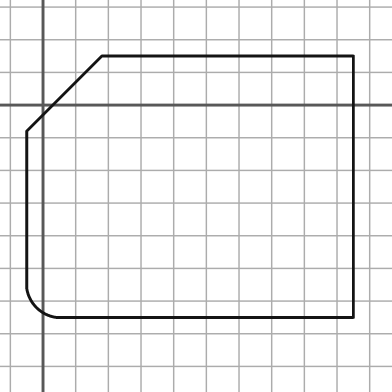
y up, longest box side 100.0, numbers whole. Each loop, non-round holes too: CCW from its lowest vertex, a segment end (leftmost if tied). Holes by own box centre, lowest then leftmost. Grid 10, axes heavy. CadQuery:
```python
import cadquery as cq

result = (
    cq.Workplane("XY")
    .moveTo(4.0, -65.0)
    .lineTo(95.0, -65.0)
    .lineTo(95.0, 15.0)
    .lineTo(18.0, 15.0)
    .lineTo(-5.0, -8.0)
    .lineTo(-5.0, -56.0)
    .threePointArc((-2.0, -62.0), (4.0, -65.0))
    .close()
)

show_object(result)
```